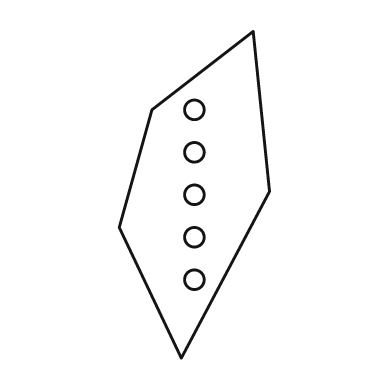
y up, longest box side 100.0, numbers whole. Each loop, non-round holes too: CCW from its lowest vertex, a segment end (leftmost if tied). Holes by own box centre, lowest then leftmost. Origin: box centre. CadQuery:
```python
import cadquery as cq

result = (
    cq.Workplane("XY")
    .moveTo(-4.0, -50.0)
    .lineTo(23.0, 1.0)
    .lineTo(18.0, 50.0)
    .lineTo(-13.0, 26.0)
    .lineTo(-23.0, -10.0)
    .close()
    .moveTo(0.0, -26.0)
    .circle(3.0)
    .moveTo(0.0, -13.0)
    .circle(3.0)
    .moveTo(0.0, 0.0)
    .circle(3.0)
    .moveTo(0.0, 13.0)
    .circle(3.0)
    .moveTo(0.0, 26.0)
    .circle(3.0)
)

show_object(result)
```